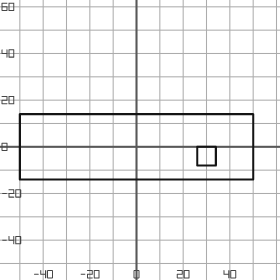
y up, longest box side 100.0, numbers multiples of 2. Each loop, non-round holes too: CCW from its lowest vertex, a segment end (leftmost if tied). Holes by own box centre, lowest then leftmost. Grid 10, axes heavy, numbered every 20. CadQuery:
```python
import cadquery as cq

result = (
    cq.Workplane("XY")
    .moveTo(-50.0, -14.0)
    .lineTo(50.0, -14.0)
    .lineTo(50.0, 14.0)
    .lineTo(-50.0, 14.0)
    .close()
    .moveTo(26.0, -8.0)
    .lineTo(34.0, -8.0)
    .lineTo(34.0, 0.0)
    .lineTo(26.0, 0.0)
    .close()
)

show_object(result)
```